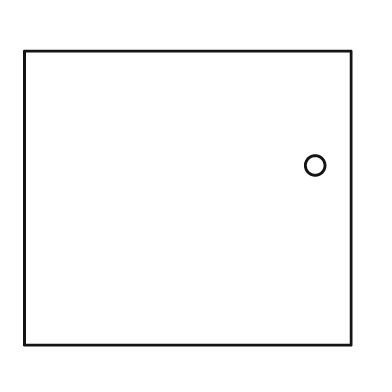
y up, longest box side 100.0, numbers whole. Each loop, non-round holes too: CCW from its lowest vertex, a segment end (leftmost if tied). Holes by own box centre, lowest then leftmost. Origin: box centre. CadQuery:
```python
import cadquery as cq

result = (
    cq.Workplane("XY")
    .moveTo(-50.0, -45.0)
    .lineTo(50.0, -45.0)
    .lineTo(50.0, 45.0)
    .lineTo(-50.0, 45.0)
    .close()
    .moveTo(39.0, 10.0)
    .circle(3.0)
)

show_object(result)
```